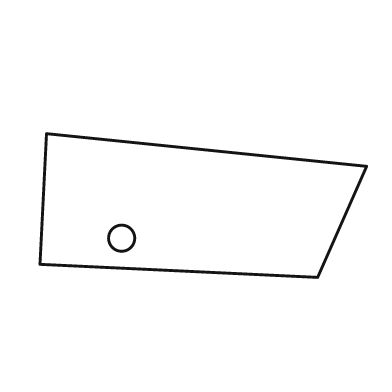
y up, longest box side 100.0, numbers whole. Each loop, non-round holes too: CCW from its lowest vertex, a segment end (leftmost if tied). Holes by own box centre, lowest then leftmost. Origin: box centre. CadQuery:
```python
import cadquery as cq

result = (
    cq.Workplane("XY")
    .moveTo(35.0, -22.0)
    .lineTo(50.0, 12.0)
    .lineTo(-48.0, 22.0)
    .lineTo(-50.0, -18.0)
    .close()
    .moveTo(-25.0, -10.0)
    .circle(4.0)
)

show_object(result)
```